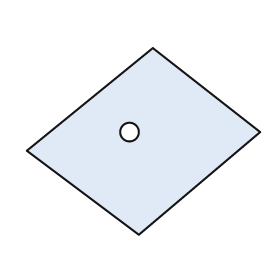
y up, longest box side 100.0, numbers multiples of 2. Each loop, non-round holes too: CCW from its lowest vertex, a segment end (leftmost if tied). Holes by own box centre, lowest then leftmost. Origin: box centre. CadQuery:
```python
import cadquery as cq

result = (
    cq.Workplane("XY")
    .moveTo(-2.0, -40.0)
    .lineTo(50.0, 4.0)
    .lineTo(4.0, 40.0)
    .lineTo(-50.0, -4.0)
    .close()
    .moveTo(-6.0, 4.0)
    .circle(4.0)
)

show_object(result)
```